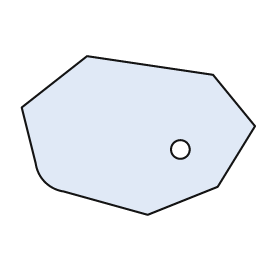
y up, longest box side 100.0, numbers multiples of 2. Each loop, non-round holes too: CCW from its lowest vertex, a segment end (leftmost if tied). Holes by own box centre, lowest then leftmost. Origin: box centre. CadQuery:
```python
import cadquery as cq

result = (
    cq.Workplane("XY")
    .moveTo(4.0, -34.0)
    .lineTo(34.0, -22.0)
    .lineTo(50.0, 4.0)
    .lineTo(32.0, 26.0)
    .lineTo(-22.0, 34.0)
    .lineTo(-50.0, 12.0)
    .lineTo(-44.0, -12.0)
    .threePointArc((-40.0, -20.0), (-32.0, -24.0))
    .close()
    .moveTo(18.0, -6.0)
    .circle(4.0)
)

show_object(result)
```